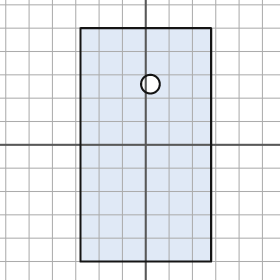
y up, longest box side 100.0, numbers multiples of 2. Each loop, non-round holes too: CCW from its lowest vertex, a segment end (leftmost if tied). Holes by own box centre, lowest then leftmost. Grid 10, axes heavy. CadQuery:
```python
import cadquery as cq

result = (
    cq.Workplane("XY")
    .moveTo(-28.0, -50.0)
    .lineTo(28.0, -50.0)
    .lineTo(28.0, 50.0)
    .lineTo(-28.0, 50.0)
    .close()
    .moveTo(2.0, 26.0)
    .circle(4.0)
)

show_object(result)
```